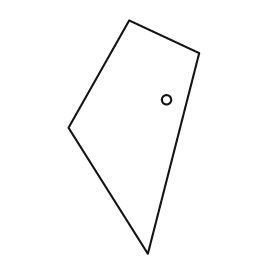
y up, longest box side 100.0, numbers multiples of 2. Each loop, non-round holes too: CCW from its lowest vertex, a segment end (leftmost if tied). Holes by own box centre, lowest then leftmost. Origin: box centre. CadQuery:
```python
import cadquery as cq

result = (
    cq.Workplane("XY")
    .moveTo(6.0, -50.0)
    .lineTo(28.0, 36.0)
    .lineTo(-2.0, 50.0)
    .lineTo(-28.0, 4.0)
    .close()
    .moveTo(14.0, 16.0)
    .circle(2.0)
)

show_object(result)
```